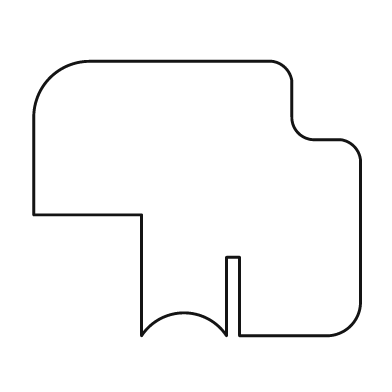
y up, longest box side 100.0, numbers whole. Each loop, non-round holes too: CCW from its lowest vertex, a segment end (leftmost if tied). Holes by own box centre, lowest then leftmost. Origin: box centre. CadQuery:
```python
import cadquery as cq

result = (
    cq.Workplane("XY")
    .moveTo(-17.0, -42.0)
    .threePointArc((-4.0, -35.0), (9.0, -42.0))
    .lineTo(9.0, -18.0)
    .lineTo(13.0, -18.0)
    .lineTo(13.0, -42.0)
    .lineTo(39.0, -42.0)
    .threePointArc((47.0, -39.0), (50.0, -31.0))
    .lineTo(50.0, 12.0)
    .threePointArc((48.0, 16.0), (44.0, 18.0))
    .lineTo(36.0, 18.0)
    .threePointArc((31.0, 20.0), (29.0, 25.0))
    .lineTo(29.0, 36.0)
    .threePointArc((27.0, 40.0), (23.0, 42.0))
    .lineTo(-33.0, 42.0)
    .threePointArc((-45.0, 37.0), (-50.0, 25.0))
    .lineTo(-50.0, -5.0)
    .lineTo(-17.0, -5.0)
    .close()
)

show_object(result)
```